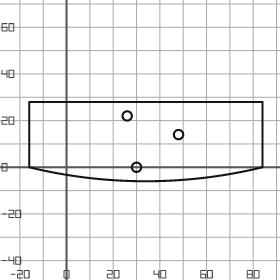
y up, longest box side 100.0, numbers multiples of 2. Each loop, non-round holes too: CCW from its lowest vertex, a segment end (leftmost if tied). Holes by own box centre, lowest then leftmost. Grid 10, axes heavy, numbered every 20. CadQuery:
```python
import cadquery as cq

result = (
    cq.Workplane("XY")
    .moveTo(-16.0, 0.0)
    .threePointArc((34.0, -6.0), (84.0, 0.0))
    .lineTo(84.0, 28.0)
    .lineTo(-16.0, 28.0)
    .close()
    .moveTo(30.0, 0.0)
    .circle(2.0)
    .moveTo(48.0, 14.0)
    .circle(2.0)
    .moveTo(26.0, 22.0)
    .circle(2.0)
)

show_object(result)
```